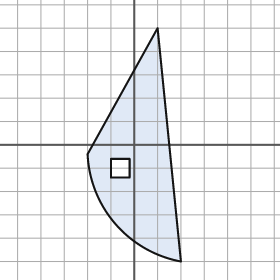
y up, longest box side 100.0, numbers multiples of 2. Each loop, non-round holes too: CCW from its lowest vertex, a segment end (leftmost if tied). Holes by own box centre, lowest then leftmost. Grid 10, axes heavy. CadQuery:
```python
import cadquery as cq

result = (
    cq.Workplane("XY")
    .moveTo(20.0, -50.0)
    .lineTo(10.0, 50.0)
    .lineTo(-20.0, -4.0)
    .threePointArc((-8.0, -34.0), (20.0, -50.0))
    .close()
    .moveTo(-10.0, -14.0)
    .lineTo(-2.0, -14.0)
    .lineTo(-2.0, -6.0)
    .lineTo(-10.0, -6.0)
    .close()
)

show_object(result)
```